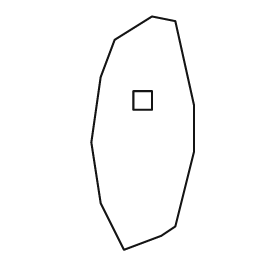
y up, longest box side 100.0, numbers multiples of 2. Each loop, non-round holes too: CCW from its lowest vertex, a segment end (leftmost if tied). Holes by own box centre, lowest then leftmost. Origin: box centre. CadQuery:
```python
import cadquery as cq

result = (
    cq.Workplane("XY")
    .moveTo(-8.0, -50.0)
    .lineTo(8.0, -44.0)
    .lineTo(14.0, -40.0)
    .lineTo(22.0, -8.0)
    .lineTo(22.0, 12.0)
    .lineTo(14.0, 48.0)
    .lineTo(4.0, 50.0)
    .lineTo(-12.0, 40.0)
    .lineTo(-18.0, 24.0)
    .lineTo(-22.0, -4.0)
    .lineTo(-18.0, -30.0)
    .close()
    .moveTo(-4.0, 10.0)
    .lineTo(4.0, 10.0)
    .lineTo(4.0, 18.0)
    .lineTo(-4.0, 18.0)
    .close()
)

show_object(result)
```